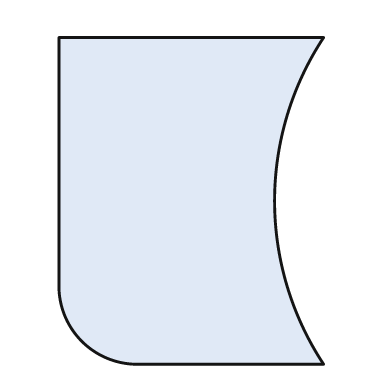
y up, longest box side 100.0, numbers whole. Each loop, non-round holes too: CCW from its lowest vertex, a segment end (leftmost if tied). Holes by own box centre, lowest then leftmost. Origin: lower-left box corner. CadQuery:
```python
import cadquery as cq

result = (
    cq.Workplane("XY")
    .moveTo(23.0, 0.0)
    .lineTo(81.0, 0.0)
    .threePointArc((66.0, 50.0), (81.0, 100.0))
    .lineTo(0.0, 100.0)
    .lineTo(0.0, 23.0)
    .threePointArc((7.0, 7.0), (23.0, 0.0))
    .close()
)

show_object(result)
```